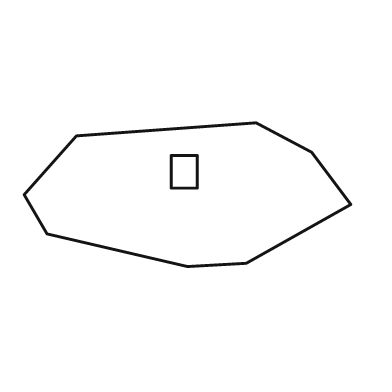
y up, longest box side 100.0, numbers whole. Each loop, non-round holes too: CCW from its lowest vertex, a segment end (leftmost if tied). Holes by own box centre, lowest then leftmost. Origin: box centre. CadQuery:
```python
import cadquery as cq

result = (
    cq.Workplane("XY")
    .moveTo(0.0, -22.0)
    .lineTo(18.0, -21.0)
    .lineTo(50.0, -3.0)
    .lineTo(38.0, 13.0)
    .lineTo(21.0, 22.0)
    .lineTo(-34.0, 18.0)
    .lineTo(-50.0, 0.0)
    .lineTo(-43.0, -12.0)
    .close()
    .moveTo(-5.0, 2.0)
    .lineTo(3.0, 2.0)
    .lineTo(3.0, 12.0)
    .lineTo(-5.0, 12.0)
    .close()
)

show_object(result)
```